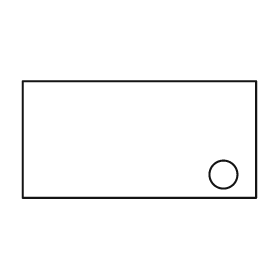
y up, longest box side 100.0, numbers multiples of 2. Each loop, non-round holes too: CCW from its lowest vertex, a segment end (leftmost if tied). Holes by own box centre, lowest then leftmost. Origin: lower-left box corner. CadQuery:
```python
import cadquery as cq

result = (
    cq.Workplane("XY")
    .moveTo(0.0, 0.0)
    .lineTo(100.0, 0.0)
    .lineTo(100.0, 50.0)
    .lineTo(0.0, 50.0)
    .close()
    .moveTo(86.0, 10.0)
    .circle(6.0)
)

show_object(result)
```